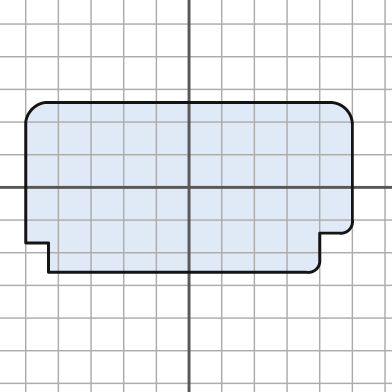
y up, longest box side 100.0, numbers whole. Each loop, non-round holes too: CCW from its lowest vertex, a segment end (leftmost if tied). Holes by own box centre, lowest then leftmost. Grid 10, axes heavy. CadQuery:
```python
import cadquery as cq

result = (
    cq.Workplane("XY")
    .moveTo(-43.0, -26.0)
    .lineTo(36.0, -26.0)
    .threePointArc((39.0, -25.0), (40.0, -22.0))
    .lineTo(40.0, -14.0)
    .lineTo(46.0, -14.0)
    .threePointArc((49.0, -13.0), (50.0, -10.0))
    .lineTo(50.0, 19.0)
    .threePointArc((48.0, 24.0), (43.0, 26.0))
    .lineTo(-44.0, 26.0)
    .threePointArc((-48.0, 24.0), (-50.0, 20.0))
    .lineTo(-50.0, -17.0)
    .lineTo(-43.0, -17.0)
    .close()
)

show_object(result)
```